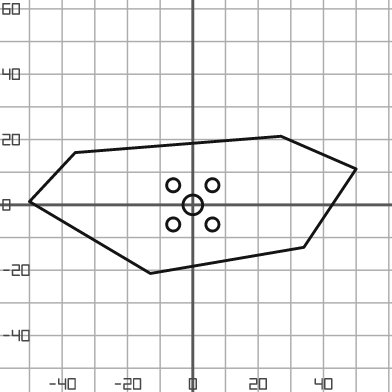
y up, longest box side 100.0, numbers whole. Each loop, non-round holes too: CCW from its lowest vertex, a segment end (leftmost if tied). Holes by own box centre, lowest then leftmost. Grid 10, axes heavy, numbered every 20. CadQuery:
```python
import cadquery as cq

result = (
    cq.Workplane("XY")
    .moveTo(-13.0, -21.0)
    .lineTo(34.0, -13.0)
    .lineTo(50.0, 11.0)
    .lineTo(27.0, 21.0)
    .lineTo(-36.0, 16.0)
    .lineTo(-50.0, 1.0)
    .close()
    .moveTo(-6.0, -6.0)
    .circle(2.0)
    .moveTo(6.0, -6.0)
    .circle(2.0)
    .moveTo(0.0, 0.0)
    .circle(3.0)
    .moveTo(-6.0, 6.0)
    .circle(2.0)
    .moveTo(6.0, 6.0)
    .circle(2.0)
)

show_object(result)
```